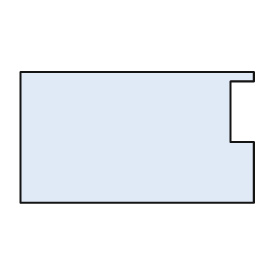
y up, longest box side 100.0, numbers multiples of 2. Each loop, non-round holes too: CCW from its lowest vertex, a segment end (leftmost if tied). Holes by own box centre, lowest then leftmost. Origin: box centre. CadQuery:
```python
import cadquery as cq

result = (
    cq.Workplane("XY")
    .moveTo(-50.0, -28.0)
    .lineTo(50.0, -28.0)
    .lineTo(50.0, -2.0)
    .lineTo(40.0, -2.0)
    .lineTo(40.0, 24.0)
    .lineTo(50.0, 24.0)
    .lineTo(50.0, 28.0)
    .lineTo(-50.0, 28.0)
    .close()
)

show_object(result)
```